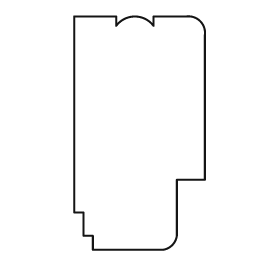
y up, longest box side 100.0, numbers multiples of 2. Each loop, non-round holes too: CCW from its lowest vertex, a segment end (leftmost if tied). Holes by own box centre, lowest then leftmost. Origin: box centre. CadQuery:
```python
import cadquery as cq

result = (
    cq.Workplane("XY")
    .moveTo(-20.0, -50.0)
    .lineTo(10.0, -50.0)
    .threePointArc((14.0, -48.0), (16.0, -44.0))
    .lineTo(16.0, -20.0)
    .lineTo(28.0, -20.0)
    .lineTo(28.0, 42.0)
    .threePointArc((26.0, 48.0), (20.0, 50.0))
    .lineTo(6.0, 50.0)
    .lineTo(6.0, 46.0)
    .threePointArc((-2.0, 50.0), (-10.0, 46.0))
    .lineTo(-10.0, 50.0)
    .lineTo(-28.0, 50.0)
    .lineTo(-28.0, -34.0)
    .lineTo(-24.0, -34.0)
    .lineTo(-24.0, -44.0)
    .lineTo(-20.0, -44.0)
    .close()
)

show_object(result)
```